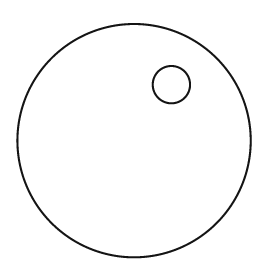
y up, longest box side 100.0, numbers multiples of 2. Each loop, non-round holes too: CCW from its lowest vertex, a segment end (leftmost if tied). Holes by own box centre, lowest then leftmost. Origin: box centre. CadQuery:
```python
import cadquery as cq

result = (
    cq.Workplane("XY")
    .moveTo(0.0, 0.0)
    .circle(50.0)
    .moveTo(16.0, 24.0)
    .circle(8.0)
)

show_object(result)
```